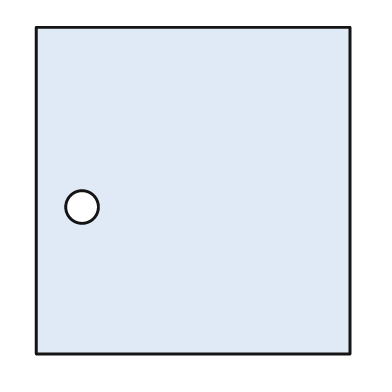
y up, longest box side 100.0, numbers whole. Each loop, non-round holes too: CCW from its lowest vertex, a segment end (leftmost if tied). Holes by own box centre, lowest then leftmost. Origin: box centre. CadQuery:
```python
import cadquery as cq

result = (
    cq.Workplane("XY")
    .moveTo(-48.0, -50.0)
    .lineTo(48.0, -50.0)
    .lineTo(48.0, 50.0)
    .lineTo(-48.0, 50.0)
    .close()
    .moveTo(-34.0, -5.0)
    .circle(5.0)
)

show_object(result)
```